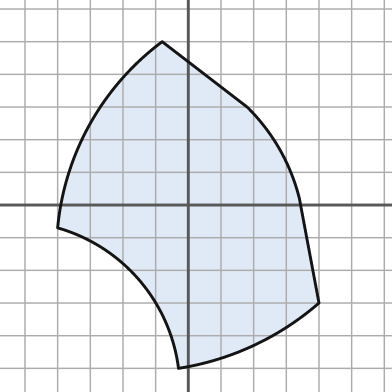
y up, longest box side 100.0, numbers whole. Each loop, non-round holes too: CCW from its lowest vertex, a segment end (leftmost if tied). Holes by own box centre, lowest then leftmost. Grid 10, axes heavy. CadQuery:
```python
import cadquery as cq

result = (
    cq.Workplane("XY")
    .moveTo(-3.0, -50.0)
    .threePointArc((20.0, -43.0), (40.0, -30.0))
    .lineTo(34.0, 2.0)
    .threePointArc((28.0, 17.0), (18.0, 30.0))
    .lineTo(-8.0, 50.0)
    .threePointArc((-30.0, 25.0), (-40.0, -7.0))
    .threePointArc((-15.0, -23.0), (-3.0, -50.0))
    .close()
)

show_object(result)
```